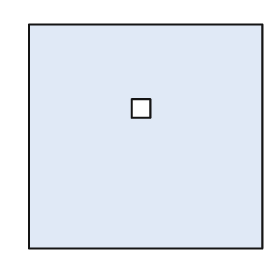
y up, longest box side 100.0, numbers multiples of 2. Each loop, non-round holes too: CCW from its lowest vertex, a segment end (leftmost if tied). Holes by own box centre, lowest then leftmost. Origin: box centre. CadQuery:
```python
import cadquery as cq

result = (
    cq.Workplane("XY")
    .moveTo(-50.0, -48.0)
    .lineTo(50.0, -48.0)
    .lineTo(50.0, 48.0)
    .lineTo(-50.0, 48.0)
    .close()
    .moveTo(-6.0, 8.0)
    .lineTo(2.0, 8.0)
    .lineTo(2.0, 16.0)
    .lineTo(-6.0, 16.0)
    .close()
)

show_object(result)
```